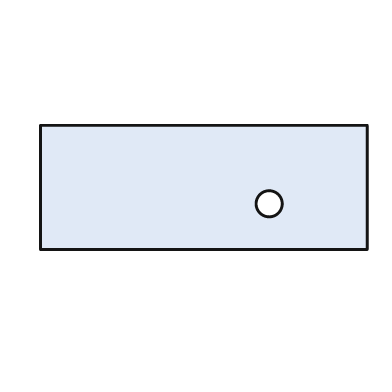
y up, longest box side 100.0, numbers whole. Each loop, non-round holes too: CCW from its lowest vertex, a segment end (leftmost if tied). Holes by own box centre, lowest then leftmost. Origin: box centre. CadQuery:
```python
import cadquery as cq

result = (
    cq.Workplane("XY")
    .moveTo(-50.0, -19.0)
    .lineTo(50.0, -19.0)
    .lineTo(50.0, 19.0)
    .lineTo(-50.0, 19.0)
    .close()
    .moveTo(20.0, -5.0)
    .circle(4.0)
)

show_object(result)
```